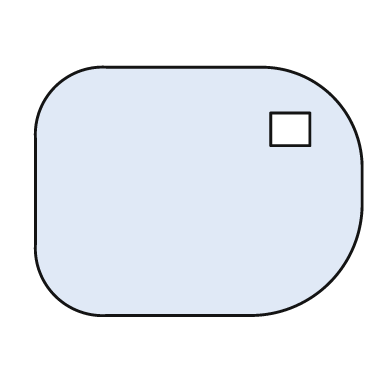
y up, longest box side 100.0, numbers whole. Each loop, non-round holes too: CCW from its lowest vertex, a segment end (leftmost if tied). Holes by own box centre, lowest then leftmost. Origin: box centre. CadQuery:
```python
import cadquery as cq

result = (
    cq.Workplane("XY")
    .moveTo(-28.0, -38.0)
    .lineTo(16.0, -38.0)
    .threePointArc((40.0, -28.0), (50.0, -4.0))
    .lineTo(50.0, 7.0)
    .threePointArc((41.0, 29.0), (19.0, 38.0))
    .lineTo(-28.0, 38.0)
    .threePointArc((-44.0, 32.0), (-50.0, 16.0))
    .lineTo(-50.0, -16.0)
    .threePointArc((-44.0, -32.0), (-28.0, -38.0))
    .close()
    .moveTo(22.0, 14.0)
    .lineTo(34.0, 14.0)
    .lineTo(34.0, 24.0)
    .lineTo(22.0, 24.0)
    .close()
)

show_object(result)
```